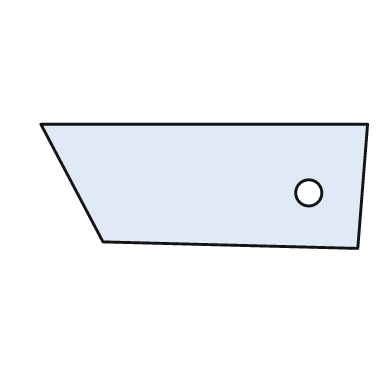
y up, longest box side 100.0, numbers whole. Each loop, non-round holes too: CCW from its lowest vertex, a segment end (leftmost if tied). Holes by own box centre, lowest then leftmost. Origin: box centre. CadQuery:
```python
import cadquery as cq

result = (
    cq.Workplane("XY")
    .moveTo(47.0, -19.0)
    .lineTo(50.0, 19.0)
    .lineTo(-50.0, 19.0)
    .lineTo(-31.0, -17.0)
    .close()
    .moveTo(32.0, -2.0)
    .circle(4.0)
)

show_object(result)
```